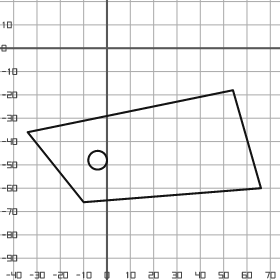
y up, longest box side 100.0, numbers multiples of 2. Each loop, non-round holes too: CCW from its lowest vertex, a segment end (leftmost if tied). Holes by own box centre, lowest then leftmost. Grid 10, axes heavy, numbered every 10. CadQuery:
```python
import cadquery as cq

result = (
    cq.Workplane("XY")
    .moveTo(-10.0, -66.0)
    .lineTo(66.0, -60.0)
    .lineTo(54.0, -18.0)
    .lineTo(-34.0, -36.0)
    .close()
    .moveTo(-4.0, -48.0)
    .circle(4.0)
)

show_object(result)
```